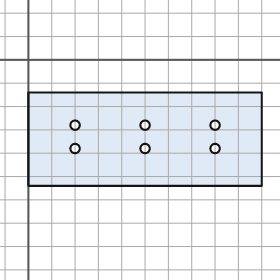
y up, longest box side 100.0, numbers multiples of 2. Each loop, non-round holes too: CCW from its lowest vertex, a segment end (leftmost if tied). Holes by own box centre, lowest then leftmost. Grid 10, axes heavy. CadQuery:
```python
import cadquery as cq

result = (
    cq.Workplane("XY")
    .moveTo(0.0, -54.0)
    .lineTo(100.0, -54.0)
    .lineTo(100.0, -14.0)
    .lineTo(0.0, -14.0)
    .close()
    .moveTo(20.0, -38.0)
    .circle(2.0)
    .moveTo(50.0, -38.0)
    .circle(2.0)
    .moveTo(80.0, -38.0)
    .circle(2.0)
    .moveTo(20.0, -28.0)
    .circle(2.0)
    .moveTo(50.0, -28.0)
    .circle(2.0)
    .moveTo(80.0, -28.0)
    .circle(2.0)
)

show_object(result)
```